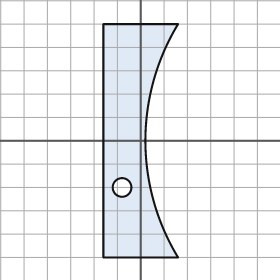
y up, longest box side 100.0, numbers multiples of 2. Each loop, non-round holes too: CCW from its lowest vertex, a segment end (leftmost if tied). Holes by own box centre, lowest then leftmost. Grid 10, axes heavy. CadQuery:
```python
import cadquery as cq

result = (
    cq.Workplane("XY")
    .moveTo(-16.0, -50.0)
    .lineTo(16.0, -50.0)
    .threePointArc((2.0, 0.0), (16.0, 50.0))
    .lineTo(-16.0, 50.0)
    .close()
    .moveTo(-8.0, -20.0)
    .circle(4.0)
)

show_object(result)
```